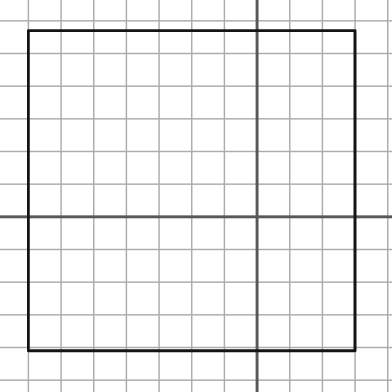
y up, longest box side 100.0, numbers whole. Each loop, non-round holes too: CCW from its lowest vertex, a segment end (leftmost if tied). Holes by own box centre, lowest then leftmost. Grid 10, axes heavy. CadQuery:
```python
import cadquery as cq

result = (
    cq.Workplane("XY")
    .moveTo(-70.0, -41.0)
    .lineTo(30.0, -41.0)
    .lineTo(30.0, 57.0)
    .lineTo(-70.0, 57.0)
    .close()
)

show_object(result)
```